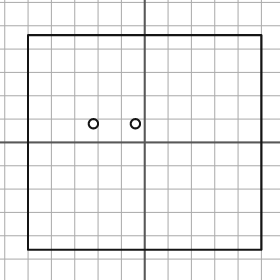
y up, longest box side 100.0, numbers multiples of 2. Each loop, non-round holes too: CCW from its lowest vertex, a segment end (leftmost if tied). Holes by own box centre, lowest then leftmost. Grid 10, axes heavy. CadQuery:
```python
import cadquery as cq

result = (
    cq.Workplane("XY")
    .moveTo(-50.0, -46.0)
    .lineTo(50.0, -46.0)
    .lineTo(50.0, 46.0)
    .lineTo(-50.0, 46.0)
    .close()
    .moveTo(-22.0, 8.0)
    .circle(2.0)
    .moveTo(-4.0, 8.0)
    .circle(2.0)
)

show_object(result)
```